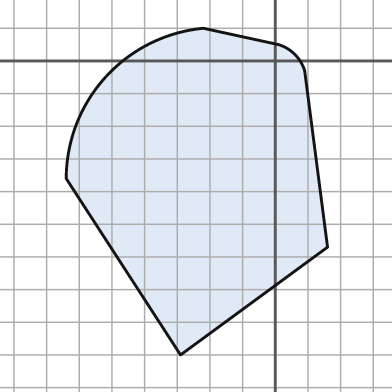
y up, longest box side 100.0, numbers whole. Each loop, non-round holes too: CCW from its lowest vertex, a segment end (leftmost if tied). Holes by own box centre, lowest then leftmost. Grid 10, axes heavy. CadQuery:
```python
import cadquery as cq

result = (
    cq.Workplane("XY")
    .moveTo(-29.0, -90.0)
    .lineTo(16.0, -57.0)
    .lineTo(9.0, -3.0)
    .threePointArc((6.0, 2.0), (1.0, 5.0))
    .lineTo(-22.0, 10.0)
    .threePointArc((-52.0, -5.0), (-64.0, -36.0))
    .close()
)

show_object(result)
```